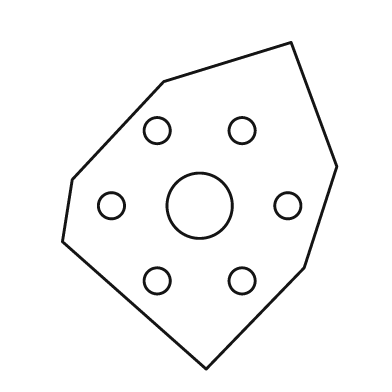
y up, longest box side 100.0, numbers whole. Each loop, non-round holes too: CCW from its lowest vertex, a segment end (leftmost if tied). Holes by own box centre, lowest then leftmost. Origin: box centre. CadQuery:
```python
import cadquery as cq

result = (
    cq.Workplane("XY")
    .moveTo(2.0, -50.0)
    .lineTo(32.0, -19.0)
    .lineTo(42.0, 12.0)
    .lineTo(28.0, 50.0)
    .lineTo(-11.0, 38.0)
    .lineTo(-39.0, 8.0)
    .lineTo(-42.0, -11.0)
    .close()
    .moveTo(-13.0, -23.0)
    .circle(4.0)
    .moveTo(13.0, -23.0)
    .circle(4.0)
    .moveTo(-27.0, 0.0)
    .circle(4.0)
    .moveTo(0.0, 0.0)
    .circle(10.0)
    .moveTo(27.0, 0.0)
    .circle(4.0)
    .moveTo(-13.0, 23.0)
    .circle(4.0)
    .moveTo(13.0, 23.0)
    .circle(4.0)
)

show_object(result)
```